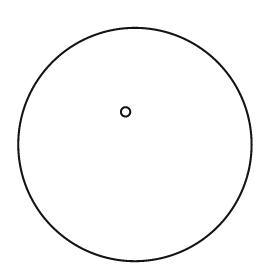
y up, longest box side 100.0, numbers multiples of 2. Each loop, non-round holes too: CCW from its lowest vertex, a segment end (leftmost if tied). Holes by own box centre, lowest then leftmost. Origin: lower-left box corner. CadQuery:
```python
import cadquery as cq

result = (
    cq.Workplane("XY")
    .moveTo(50.0, 50.0)
    .circle(50.0)
    .moveTo(46.0, 64.0)
    .circle(2.0)
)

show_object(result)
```